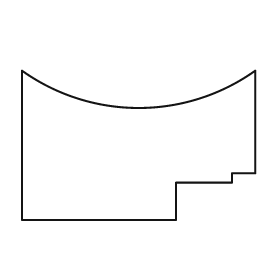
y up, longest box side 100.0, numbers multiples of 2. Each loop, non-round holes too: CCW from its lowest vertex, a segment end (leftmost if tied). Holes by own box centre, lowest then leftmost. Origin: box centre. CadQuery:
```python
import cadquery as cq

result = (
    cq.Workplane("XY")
    .moveTo(-50.0, -32.0)
    .lineTo(16.0, -32.0)
    .lineTo(16.0, -16.0)
    .lineTo(40.0, -16.0)
    .lineTo(40.0, -12.0)
    .lineTo(50.0, -12.0)
    .lineTo(50.0, 32.0)
    .threePointArc((0.0, 16.0), (-50.0, 32.0))
    .close()
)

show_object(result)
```